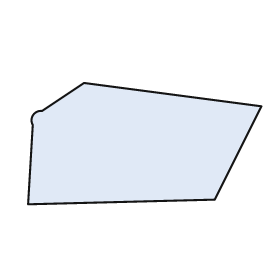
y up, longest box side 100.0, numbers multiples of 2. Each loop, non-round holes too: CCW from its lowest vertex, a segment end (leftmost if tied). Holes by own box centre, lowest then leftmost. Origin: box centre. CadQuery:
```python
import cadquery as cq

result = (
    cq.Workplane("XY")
    .moveTo(-50.0, -26.0)
    .lineTo(30.0, -24.0)
    .lineTo(50.0, 16.0)
    .lineTo(-26.0, 26.0)
    .lineTo(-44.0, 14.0)
    .threePointArc((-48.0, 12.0), (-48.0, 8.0))
    .close()
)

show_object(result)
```